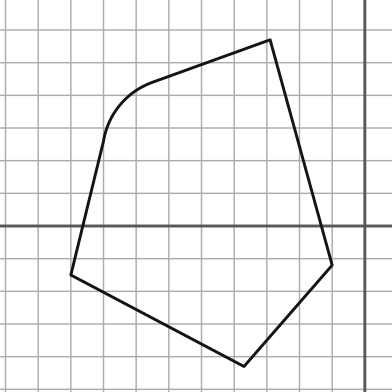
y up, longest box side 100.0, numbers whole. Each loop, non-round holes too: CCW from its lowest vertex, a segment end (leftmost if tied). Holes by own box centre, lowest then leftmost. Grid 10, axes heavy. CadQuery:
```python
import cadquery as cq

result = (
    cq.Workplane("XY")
    .moveTo(-37.0, -43.0)
    .lineTo(-10.0, -12.0)
    .lineTo(-29.0, 57.0)
    .lineTo(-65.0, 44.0)
    .threePointArc((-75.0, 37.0), (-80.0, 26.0))
    .lineTo(-90.0, -15.0)
    .close()
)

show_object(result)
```